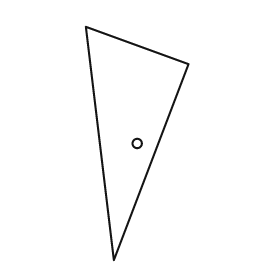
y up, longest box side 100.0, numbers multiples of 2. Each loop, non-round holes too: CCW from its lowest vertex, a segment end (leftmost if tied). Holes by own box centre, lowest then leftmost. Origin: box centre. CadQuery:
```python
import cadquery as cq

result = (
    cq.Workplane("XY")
    .moveTo(-10.0, -50.0)
    .lineTo(22.0, 34.0)
    .lineTo(-22.0, 50.0)
    .close()
    .moveTo(0.0, 0.0)
    .circle(2.0)
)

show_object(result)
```